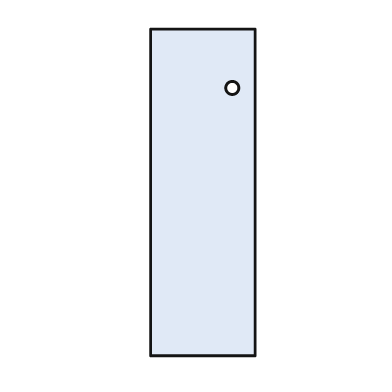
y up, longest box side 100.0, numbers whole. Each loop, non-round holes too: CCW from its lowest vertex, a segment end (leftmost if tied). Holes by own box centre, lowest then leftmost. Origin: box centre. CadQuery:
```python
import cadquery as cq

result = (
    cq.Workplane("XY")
    .moveTo(-16.0, -50.0)
    .lineTo(16.0, -50.0)
    .lineTo(16.0, 50.0)
    .lineTo(-16.0, 50.0)
    .close()
    .moveTo(9.0, 32.0)
    .circle(2.0)
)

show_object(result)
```